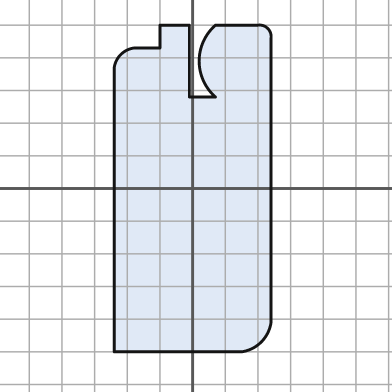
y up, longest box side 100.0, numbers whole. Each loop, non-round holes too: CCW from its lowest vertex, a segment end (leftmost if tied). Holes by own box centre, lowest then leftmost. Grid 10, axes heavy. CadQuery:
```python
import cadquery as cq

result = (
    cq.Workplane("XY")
    .moveTo(-24.0, -50.0)
    .lineTo(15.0, -50.0)
    .threePointArc((21.0, -47.0), (24.0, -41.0))
    .lineTo(24.0, 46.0)
    .threePointArc((23.0, 49.0), (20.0, 50.0))
    .lineTo(7.0, 50.0)
    .threePointArc((2.0, 39.0), (7.0, 28.0))
    .lineTo(-1.0, 28.0)
    .lineTo(-1.0, 50.0)
    .lineTo(-10.0, 50.0)
    .lineTo(-10.0, 43.0)
    .lineTo(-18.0, 43.0)
    .threePointArc((-22.0, 41.0), (-24.0, 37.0))
    .close()
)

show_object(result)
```